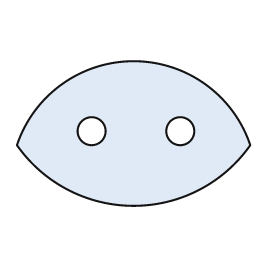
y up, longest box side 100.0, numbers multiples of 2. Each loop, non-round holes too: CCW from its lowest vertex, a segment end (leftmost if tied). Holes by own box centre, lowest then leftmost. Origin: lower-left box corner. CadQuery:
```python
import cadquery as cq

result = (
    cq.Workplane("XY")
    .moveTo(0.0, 26.0)
    .threePointArc((50.0, 0.0), (100.0, 26.0))
    .threePointArc((50.0, 62.0), (0.0, 26.0))
    .close()
    .moveTo(32.0, 32.0)
    .circle(6.0)
    .moveTo(70.0, 32.0)
    .circle(6.0)
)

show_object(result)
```